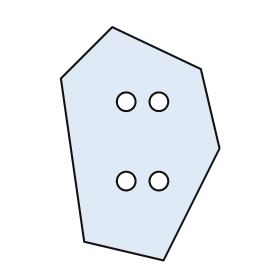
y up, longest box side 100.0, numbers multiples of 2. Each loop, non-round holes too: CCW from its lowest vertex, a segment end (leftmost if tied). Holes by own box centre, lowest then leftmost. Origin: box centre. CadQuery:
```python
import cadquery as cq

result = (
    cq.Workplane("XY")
    .moveTo(10.0, -50.0)
    .lineTo(34.0, -2.0)
    .lineTo(26.0, 32.0)
    .lineTo(-12.0, 50.0)
    .lineTo(-34.0, 28.0)
    .lineTo(-24.0, -42.0)
    .close()
    .moveTo(-6.0, -16.0)
    .circle(4.0)
    .moveTo(8.0, -16.0)
    .circle(4.0)
    .moveTo(-6.0, 18.0)
    .circle(4.0)
    .moveTo(8.0, 18.0)
    .circle(4.0)
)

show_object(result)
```